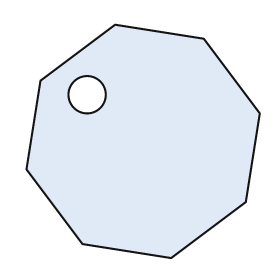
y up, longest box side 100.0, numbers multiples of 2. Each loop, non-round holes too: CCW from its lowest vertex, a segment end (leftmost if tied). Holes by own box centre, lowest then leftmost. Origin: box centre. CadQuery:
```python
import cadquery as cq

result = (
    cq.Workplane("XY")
    .moveTo(12.0, -50.0)
    .lineTo(44.0, -26.0)
    .lineTo(50.0, 12.0)
    .lineTo(26.0, 44.0)
    .lineTo(-12.0, 50.0)
    .lineTo(-44.0, 26.0)
    .lineTo(-50.0, -12.0)
    .lineTo(-26.0, -44.0)
    .close()
    .moveTo(-24.0, 20.0)
    .circle(8.0)
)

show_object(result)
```